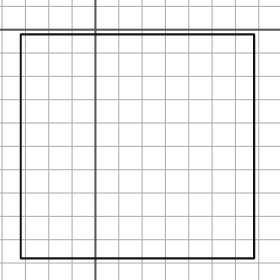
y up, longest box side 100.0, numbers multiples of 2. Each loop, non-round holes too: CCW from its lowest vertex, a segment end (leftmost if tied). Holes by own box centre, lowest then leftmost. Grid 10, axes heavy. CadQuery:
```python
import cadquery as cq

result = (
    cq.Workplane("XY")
    .moveTo(-32.0, -98.0)
    .lineTo(68.0, -98.0)
    .lineTo(68.0, -2.0)
    .lineTo(-32.0, -2.0)
    .close()
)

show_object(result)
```